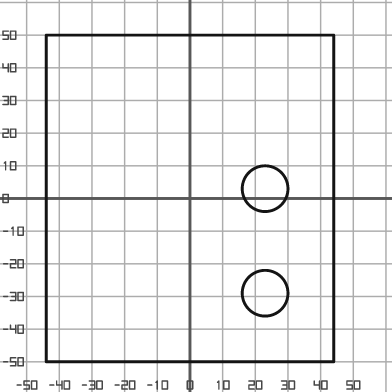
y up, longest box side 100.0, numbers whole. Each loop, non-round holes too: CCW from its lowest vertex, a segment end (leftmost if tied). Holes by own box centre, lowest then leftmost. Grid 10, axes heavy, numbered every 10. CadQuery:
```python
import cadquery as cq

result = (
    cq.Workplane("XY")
    .moveTo(-44.0, -50.0)
    .lineTo(44.0, -50.0)
    .lineTo(44.0, 50.0)
    .lineTo(-44.0, 50.0)
    .close()
    .moveTo(23.0, -29.0)
    .circle(7.0)
    .moveTo(23.0, 3.0)
    .circle(7.0)
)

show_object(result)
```